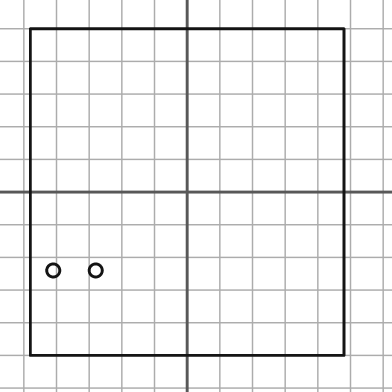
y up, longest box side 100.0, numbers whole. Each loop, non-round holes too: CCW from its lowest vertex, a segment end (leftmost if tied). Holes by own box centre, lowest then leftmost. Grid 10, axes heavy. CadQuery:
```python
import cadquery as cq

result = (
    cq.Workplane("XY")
    .moveTo(-48.0, -50.0)
    .lineTo(48.0, -50.0)
    .lineTo(48.0, 50.0)
    .lineTo(-48.0, 50.0)
    .close()
    .moveTo(-41.0, -24.0)
    .circle(2.0)
    .moveTo(-28.0, -24.0)
    .circle(2.0)
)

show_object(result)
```